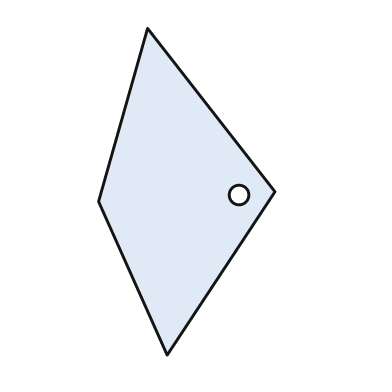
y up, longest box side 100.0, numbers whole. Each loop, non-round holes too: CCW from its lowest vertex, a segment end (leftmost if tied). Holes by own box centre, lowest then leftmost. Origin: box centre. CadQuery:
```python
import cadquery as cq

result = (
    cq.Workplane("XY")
    .moveTo(-6.0, -50.0)
    .lineTo(27.0, 0.0)
    .lineTo(-12.0, 50.0)
    .lineTo(-27.0, -3.0)
    .close()
    .moveTo(16.0, -1.0)
    .circle(3.0)
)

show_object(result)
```